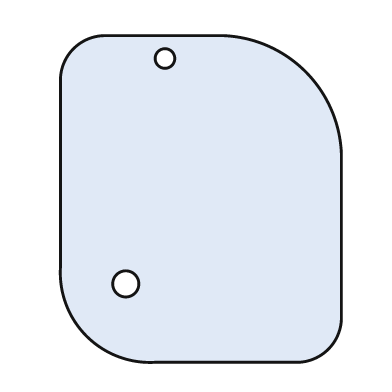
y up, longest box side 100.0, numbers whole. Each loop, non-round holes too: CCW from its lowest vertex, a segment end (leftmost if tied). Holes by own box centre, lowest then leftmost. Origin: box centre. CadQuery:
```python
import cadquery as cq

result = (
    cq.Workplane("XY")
    .moveTo(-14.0, -50.0)
    .lineTo(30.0, -50.0)
    .threePointArc((39.0, -46.0), (43.0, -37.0))
    .lineTo(43.0, 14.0)
    .threePointArc((32.0, 39.0), (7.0, 50.0))
    .lineTo(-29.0, 50.0)
    .threePointArc((-39.0, 46.0), (-43.0, 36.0))
    .lineTo(-43.0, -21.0)
    .threePointArc((-35.0, -42.0), (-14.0, -50.0))
    .close()
    .moveTo(-23.0, -26.0)
    .circle(4.0)
    .moveTo(-11.0, 43.0)
    .circle(3.0)
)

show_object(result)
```